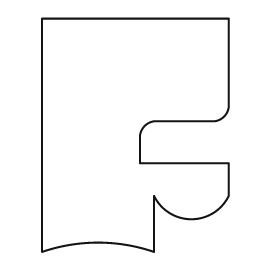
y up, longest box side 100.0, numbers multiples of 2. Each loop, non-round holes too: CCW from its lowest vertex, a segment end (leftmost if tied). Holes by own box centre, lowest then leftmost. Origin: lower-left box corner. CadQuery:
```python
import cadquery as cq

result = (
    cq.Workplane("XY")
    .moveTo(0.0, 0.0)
    .threePointArc((24.0, 4.0), (48.0, 0.0))
    .lineTo(48.0, 24.0)
    .threePointArc((64.0, 14.0), (80.0, 24.0))
    .lineTo(80.0, 38.0)
    .lineTo(42.0, 38.0)
    .lineTo(42.0, 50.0)
    .threePointArc((44.0, 54.0), (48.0, 56.0))
    .lineTo(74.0, 56.0)
    .threePointArc((78.0, 58.0), (80.0, 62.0))
    .lineTo(80.0, 100.0)
    .lineTo(0.0, 100.0)
    .close()
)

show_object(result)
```